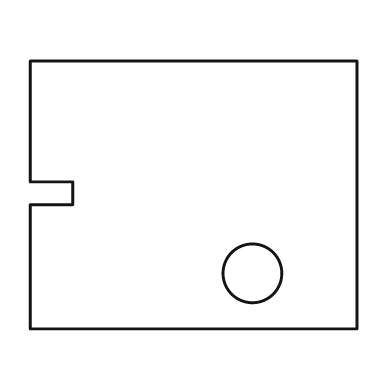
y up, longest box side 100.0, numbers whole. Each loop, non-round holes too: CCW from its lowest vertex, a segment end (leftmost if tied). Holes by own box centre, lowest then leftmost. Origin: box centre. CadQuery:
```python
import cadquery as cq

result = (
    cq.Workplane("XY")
    .moveTo(-50.0, -41.0)
    .lineTo(50.0, -41.0)
    .lineTo(50.0, 41.0)
    .lineTo(-50.0, 41.0)
    .lineTo(-50.0, 4.0)
    .lineTo(-37.0, 4.0)
    .lineTo(-37.0, -3.0)
    .lineTo(-50.0, -3.0)
    .close()
    .moveTo(18.0, -24.0)
    .circle(9.0)
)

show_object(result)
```